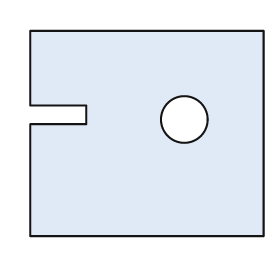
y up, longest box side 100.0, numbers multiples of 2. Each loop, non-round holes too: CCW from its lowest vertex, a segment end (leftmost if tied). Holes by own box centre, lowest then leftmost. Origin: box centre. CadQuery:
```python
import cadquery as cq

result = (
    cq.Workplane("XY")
    .moveTo(-50.0, -44.0)
    .lineTo(50.0, -44.0)
    .lineTo(50.0, 44.0)
    .lineTo(-50.0, 44.0)
    .lineTo(-50.0, 12.0)
    .lineTo(-26.0, 12.0)
    .lineTo(-26.0, 4.0)
    .lineTo(-50.0, 4.0)
    .close()
    .moveTo(16.0, 6.0)
    .circle(10.0)
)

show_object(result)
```